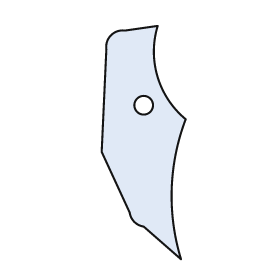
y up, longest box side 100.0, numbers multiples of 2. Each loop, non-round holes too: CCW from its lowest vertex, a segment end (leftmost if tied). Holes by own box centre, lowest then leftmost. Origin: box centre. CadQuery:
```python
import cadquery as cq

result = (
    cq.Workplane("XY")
    .moveTo(16.0, -50.0)
    .threePointArc((12.0, -20.0), (18.0, 10.0))
    .threePointArc((6.0, 28.0), (6.0, 50.0))
    .lineTo(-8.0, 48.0)
    .threePointArc((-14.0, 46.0), (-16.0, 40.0))
    .lineTo(-18.0, -4.0)
    .lineTo(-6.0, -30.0)
    .threePointArc((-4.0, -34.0), (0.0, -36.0))
    .close()
    .moveTo(0.0, 16.0)
    .circle(4.0)
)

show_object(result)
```